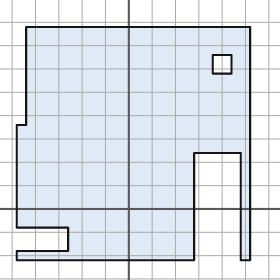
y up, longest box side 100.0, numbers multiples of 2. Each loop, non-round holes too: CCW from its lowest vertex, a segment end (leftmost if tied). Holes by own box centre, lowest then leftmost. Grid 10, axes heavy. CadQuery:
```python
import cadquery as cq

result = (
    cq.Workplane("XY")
    .moveTo(-48.0, -22.0)
    .lineTo(28.0, -22.0)
    .lineTo(28.0, 24.0)
    .lineTo(48.0, 24.0)
    .lineTo(48.0, -22.0)
    .lineTo(52.0, -22.0)
    .lineTo(52.0, 78.0)
    .lineTo(-44.0, 78.0)
    .lineTo(-44.0, 36.0)
    .lineTo(-48.0, 36.0)
    .lineTo(-48.0, -8.0)
    .lineTo(-26.0, -8.0)
    .lineTo(-26.0, -18.0)
    .lineTo(-48.0, -18.0)
    .close()
    .moveTo(36.0, 58.0)
    .lineTo(44.0, 58.0)
    .lineTo(44.0, 66.0)
    .lineTo(36.0, 66.0)
    .close()
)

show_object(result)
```